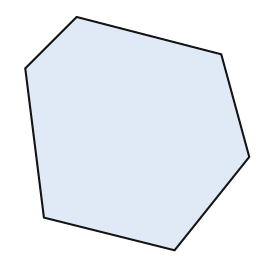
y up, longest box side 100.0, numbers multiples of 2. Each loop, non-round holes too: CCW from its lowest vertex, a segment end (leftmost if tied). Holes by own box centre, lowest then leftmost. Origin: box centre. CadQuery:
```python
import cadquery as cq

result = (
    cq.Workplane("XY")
    .moveTo(16.0, -50.0)
    .lineTo(48.0, -10.0)
    .lineTo(36.0, 34.0)
    .lineTo(-26.0, 50.0)
    .lineTo(-48.0, 28.0)
    .lineTo(-40.0, -36.0)
    .close()
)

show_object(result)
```